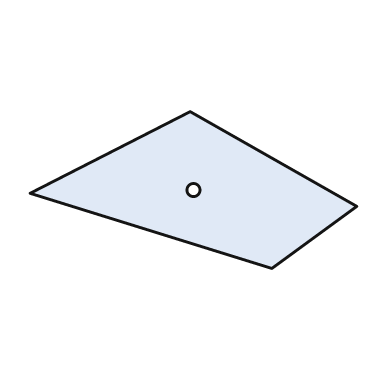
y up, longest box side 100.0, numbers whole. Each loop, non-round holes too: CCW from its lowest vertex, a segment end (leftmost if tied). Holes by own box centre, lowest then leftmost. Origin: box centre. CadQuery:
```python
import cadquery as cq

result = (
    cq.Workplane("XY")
    .moveTo(24.0, -24.0)
    .lineTo(50.0, -5.0)
    .lineTo(-1.0, 24.0)
    .lineTo(-50.0, -1.0)
    .close()
    .moveTo(0.0, 0.0)
    .circle(2.0)
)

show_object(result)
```